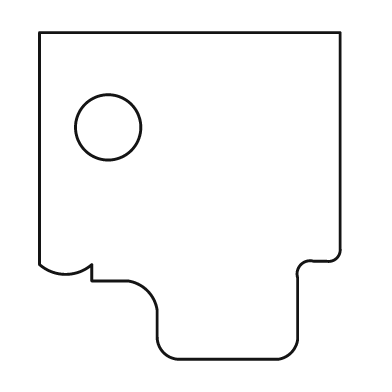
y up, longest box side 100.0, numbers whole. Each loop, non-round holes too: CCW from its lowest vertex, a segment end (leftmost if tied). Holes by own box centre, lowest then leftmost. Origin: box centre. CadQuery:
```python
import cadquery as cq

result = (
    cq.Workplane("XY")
    .moveTo(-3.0, -50.0)
    .lineTo(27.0, -50.0)
    .threePointArc((31.0, -48.0), (33.0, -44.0))
    .lineTo(33.0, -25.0)
    .threePointArc((34.0, -21.0), (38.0, -20.0))
    .lineTo(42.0, -20.0)
    .threePointArc((45.0, -19.0), (46.0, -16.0))
    .lineTo(46.0, 50.0)
    .lineTo(-46.0, 50.0)
    .lineTo(-46.0, -21.0)
    .threePointArc((-38.0, -24.0), (-30.0, -21.0))
    .lineTo(-30.0, -26.0)
    .lineTo(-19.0, -26.0)
    .threePointArc((-13.0, -29.0), (-10.0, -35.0))
    .lineTo(-10.0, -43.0)
    .threePointArc((-8.0, -48.0), (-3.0, -50.0))
    .close()
    .moveTo(-25.0, 21.0)
    .circle(10.0)
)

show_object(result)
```